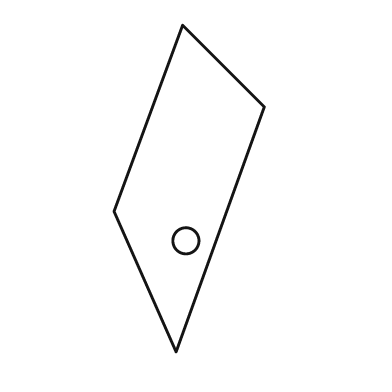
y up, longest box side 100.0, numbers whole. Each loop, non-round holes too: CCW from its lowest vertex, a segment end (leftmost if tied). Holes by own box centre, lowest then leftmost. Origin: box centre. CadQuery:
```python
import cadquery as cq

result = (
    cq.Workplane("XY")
    .moveTo(-4.0, -50.0)
    .lineTo(23.0, 25.0)
    .lineTo(-2.0, 50.0)
    .lineTo(-23.0, -7.0)
    .close()
    .moveTo(-1.0, -16.0)
    .circle(4.0)
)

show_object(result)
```